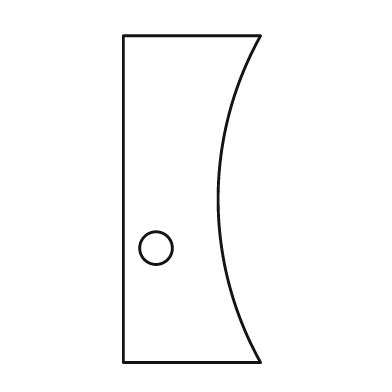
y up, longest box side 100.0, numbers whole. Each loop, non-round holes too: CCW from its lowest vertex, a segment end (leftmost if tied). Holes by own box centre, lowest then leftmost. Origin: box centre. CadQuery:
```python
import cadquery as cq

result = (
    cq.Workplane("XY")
    .moveTo(-21.0, -50.0)
    .lineTo(21.0, -50.0)
    .threePointArc((8.0, 0.0), (21.0, 50.0))
    .lineTo(-21.0, 50.0)
    .close()
    .moveTo(-11.0, -15.0)
    .circle(5.0)
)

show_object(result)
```